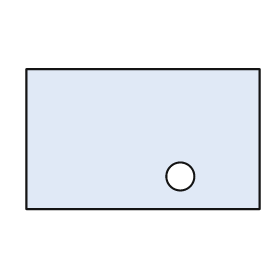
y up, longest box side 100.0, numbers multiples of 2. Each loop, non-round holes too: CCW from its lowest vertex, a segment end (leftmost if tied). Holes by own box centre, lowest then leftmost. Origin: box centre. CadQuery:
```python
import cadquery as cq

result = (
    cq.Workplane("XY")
    .moveTo(-50.0, -30.0)
    .lineTo(50.0, -30.0)
    .lineTo(50.0, 30.0)
    .lineTo(-50.0, 30.0)
    .close()
    .moveTo(16.0, -16.0)
    .circle(6.0)
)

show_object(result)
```